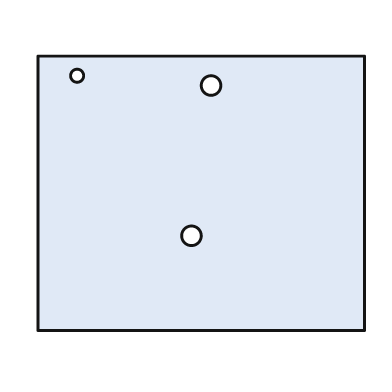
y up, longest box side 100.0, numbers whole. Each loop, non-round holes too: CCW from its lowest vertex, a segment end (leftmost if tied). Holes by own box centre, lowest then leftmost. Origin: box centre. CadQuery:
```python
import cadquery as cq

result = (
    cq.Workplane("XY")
    .moveTo(-50.0, -42.0)
    .lineTo(50.0, -42.0)
    .lineTo(50.0, 42.0)
    .lineTo(-50.0, 42.0)
    .close()
    .moveTo(-3.0, -13.0)
    .circle(3.0)
    .moveTo(3.0, 33.0)
    .circle(3.0)
    .moveTo(-38.0, 36.0)
    .circle(2.0)
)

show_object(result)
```